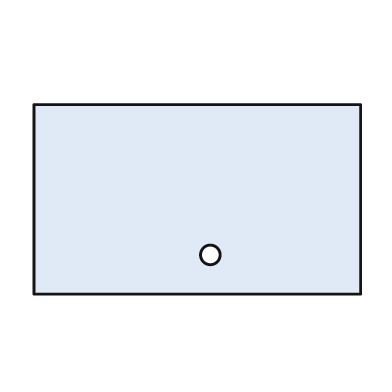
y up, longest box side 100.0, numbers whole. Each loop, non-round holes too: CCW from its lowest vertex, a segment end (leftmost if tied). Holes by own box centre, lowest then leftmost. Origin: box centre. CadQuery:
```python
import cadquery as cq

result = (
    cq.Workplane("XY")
    .moveTo(-50.0, -29.0)
    .lineTo(50.0, -29.0)
    .lineTo(50.0, 29.0)
    .lineTo(-50.0, 29.0)
    .close()
    .moveTo(4.0, -17.0)
    .circle(3.0)
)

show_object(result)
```